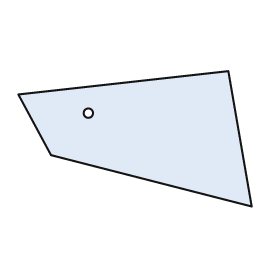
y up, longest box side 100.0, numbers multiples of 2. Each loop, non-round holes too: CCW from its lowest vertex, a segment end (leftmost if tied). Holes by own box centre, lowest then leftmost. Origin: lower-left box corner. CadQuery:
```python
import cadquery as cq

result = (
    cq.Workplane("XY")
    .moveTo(100.0, 0.0)
    .lineTo(90.0, 58.0)
    .lineTo(0.0, 48.0)
    .lineTo(14.0, 22.0)
    .close()
    .moveTo(30.0, 40.0)
    .circle(2.0)
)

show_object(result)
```